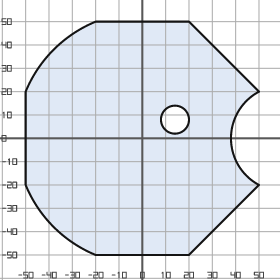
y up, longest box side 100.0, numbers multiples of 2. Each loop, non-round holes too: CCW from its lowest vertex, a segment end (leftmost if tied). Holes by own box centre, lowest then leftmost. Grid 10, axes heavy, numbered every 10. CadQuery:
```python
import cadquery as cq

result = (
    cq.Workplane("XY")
    .moveTo(-20.0, -50.0)
    .lineTo(20.0, -50.0)
    .lineTo(50.0, -20.0)
    .threePointArc((38.0, 0.0), (50.0, 20.0))
    .lineTo(20.0, 50.0)
    .lineTo(-20.0, 50.0)
    .threePointArc((-38.0, 38.0), (-50.0, 20.0))
    .lineTo(-50.0, -20.0)
    .threePointArc((-38.0, -38.0), (-20.0, -50.0))
    .close()
    .moveTo(14.0, 8.0)
    .circle(6.0)
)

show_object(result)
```